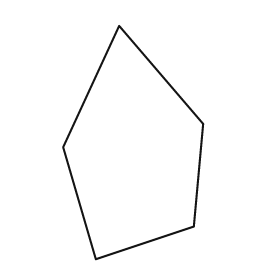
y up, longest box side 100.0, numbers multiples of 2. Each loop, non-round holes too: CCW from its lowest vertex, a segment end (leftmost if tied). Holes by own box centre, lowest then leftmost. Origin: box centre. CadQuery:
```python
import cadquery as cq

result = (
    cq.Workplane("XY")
    .moveTo(-16.0, -50.0)
    .lineTo(26.0, -36.0)
    .lineTo(30.0, 8.0)
    .lineTo(-6.0, 50.0)
    .lineTo(-30.0, -2.0)
    .close()
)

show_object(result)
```